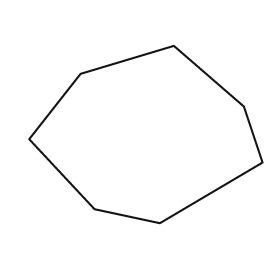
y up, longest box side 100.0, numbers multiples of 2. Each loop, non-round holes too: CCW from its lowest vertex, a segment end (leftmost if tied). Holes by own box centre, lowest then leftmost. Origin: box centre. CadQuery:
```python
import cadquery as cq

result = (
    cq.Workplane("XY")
    .moveTo(6.0, -38.0)
    .lineTo(50.0, -12.0)
    .lineTo(42.0, 12.0)
    .lineTo(12.0, 38.0)
    .lineTo(-28.0, 26.0)
    .lineTo(-50.0, -2.0)
    .lineTo(-22.0, -32.0)
    .close()
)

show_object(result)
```